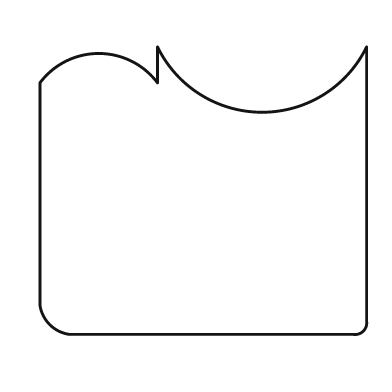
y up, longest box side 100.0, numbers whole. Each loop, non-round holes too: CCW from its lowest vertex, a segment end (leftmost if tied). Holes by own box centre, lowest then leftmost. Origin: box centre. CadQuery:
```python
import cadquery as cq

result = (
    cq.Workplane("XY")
    .moveTo(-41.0, -44.0)
    .lineTo(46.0, -44.0)
    .threePointArc((49.0, -43.0), (50.0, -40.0))
    .lineTo(50.0, 44.0)
    .threePointArc((18.0, 24.0), (-14.0, 44.0))
    .lineTo(-14.0, 33.0)
    .threePointArc((-32.0, 42.0), (-50.0, 33.0))
    .lineTo(-50.0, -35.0)
    .threePointArc((-47.0, -41.0), (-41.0, -44.0))
    .close()
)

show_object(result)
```